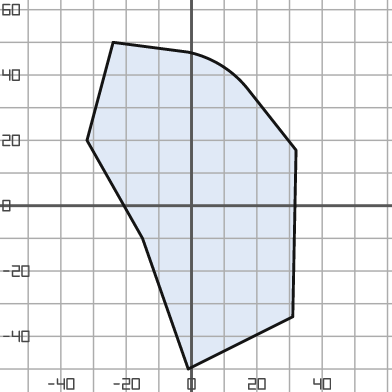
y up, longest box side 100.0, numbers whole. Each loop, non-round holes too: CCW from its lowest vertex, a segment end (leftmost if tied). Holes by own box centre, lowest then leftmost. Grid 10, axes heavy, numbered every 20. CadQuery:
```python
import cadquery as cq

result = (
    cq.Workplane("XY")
    .moveTo(-1.0, -50.0)
    .lineTo(31.0, -34.0)
    .lineTo(32.0, 17.0)
    .lineTo(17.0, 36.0)
    .threePointArc((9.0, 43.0), (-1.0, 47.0))
    .lineTo(-24.0, 50.0)
    .lineTo(-32.0, 20.0)
    .lineTo(-15.0, -10.0)
    .close()
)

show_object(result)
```